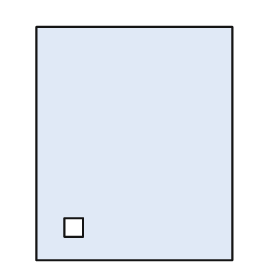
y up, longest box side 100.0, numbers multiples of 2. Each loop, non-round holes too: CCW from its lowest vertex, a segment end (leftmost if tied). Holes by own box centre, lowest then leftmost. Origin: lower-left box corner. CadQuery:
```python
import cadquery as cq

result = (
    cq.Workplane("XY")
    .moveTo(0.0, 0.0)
    .lineTo(84.0, 0.0)
    .lineTo(84.0, 100.0)
    .lineTo(0.0, 100.0)
    .close()
    .moveTo(12.0, 10.0)
    .lineTo(20.0, 10.0)
    .lineTo(20.0, 18.0)
    .lineTo(12.0, 18.0)
    .close()
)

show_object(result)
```